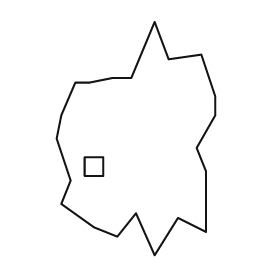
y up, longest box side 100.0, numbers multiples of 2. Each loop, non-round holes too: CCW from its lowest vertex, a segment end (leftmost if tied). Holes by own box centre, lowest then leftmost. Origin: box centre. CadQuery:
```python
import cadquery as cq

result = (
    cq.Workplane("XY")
    .moveTo(8.0, -50.0)
    .lineTo(18.0, -34.0)
    .lineTo(30.0, -40.0)
    .lineTo(30.0, -14.0)
    .lineTo(26.0, -4.0)
    .lineTo(34.0, 10.0)
    .lineTo(34.0, 18.0)
    .lineTo(28.0, 36.0)
    .lineTo(14.0, 34.0)
    .lineTo(8.0, 50.0)
    .lineTo(-2.0, 26.0)
    .lineTo(-10.0, 26.0)
    .lineTo(-20.0, 24.0)
    .lineTo(-26.0, 24.0)
    .lineTo(-32.0, 10.0)
    .lineTo(-34.0, 0.0)
    .lineTo(-28.0, -18.0)
    .lineTo(-32.0, -28.0)
    .lineTo(-18.0, -38.0)
    .lineTo(-8.0, -42.0)
    .lineTo(0.0, -32.0)
    .close()
    .moveTo(-22.0, -16.0)
    .lineTo(-14.0, -16.0)
    .lineTo(-14.0, -8.0)
    .lineTo(-22.0, -8.0)
    .close()
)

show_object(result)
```